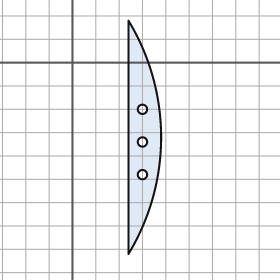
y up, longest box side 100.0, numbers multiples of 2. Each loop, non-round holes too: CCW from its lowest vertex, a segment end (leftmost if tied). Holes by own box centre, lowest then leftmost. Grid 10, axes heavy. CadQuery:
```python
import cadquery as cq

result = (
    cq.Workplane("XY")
    .moveTo(24.0, -82.0)
    .threePointArc((38.0, -32.0), (24.0, 18.0))
    .close()
    .moveTo(30.0, -48.0)
    .circle(2.0)
    .moveTo(30.0, -34.0)
    .circle(2.0)
    .moveTo(30.0, -20.0)
    .circle(2.0)
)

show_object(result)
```